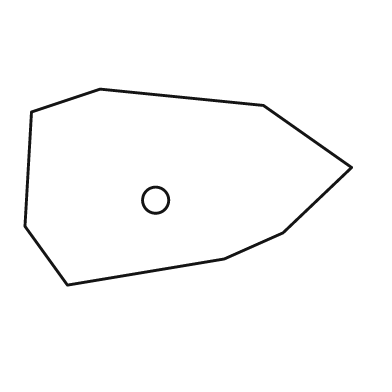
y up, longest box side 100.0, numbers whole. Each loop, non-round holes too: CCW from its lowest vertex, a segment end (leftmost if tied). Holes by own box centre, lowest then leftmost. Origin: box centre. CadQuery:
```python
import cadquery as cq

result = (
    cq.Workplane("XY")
    .moveTo(-37.0, -30.0)
    .lineTo(11.0, -22.0)
    .lineTo(29.0, -14.0)
    .lineTo(50.0, 6.0)
    .lineTo(23.0, 25.0)
    .lineTo(-27.0, 30.0)
    .lineTo(-48.0, 23.0)
    .lineTo(-50.0, -12.0)
    .close()
    .moveTo(-10.0, -4.0)
    .circle(4.0)
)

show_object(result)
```